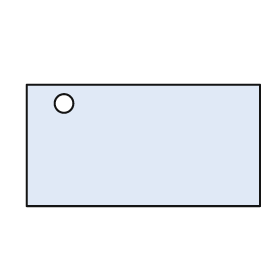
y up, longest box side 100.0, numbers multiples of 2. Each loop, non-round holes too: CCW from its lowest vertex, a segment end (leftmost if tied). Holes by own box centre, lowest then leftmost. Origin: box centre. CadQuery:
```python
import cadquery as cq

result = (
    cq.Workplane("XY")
    .moveTo(-50.0, -26.0)
    .lineTo(50.0, -26.0)
    .lineTo(50.0, 26.0)
    .lineTo(-50.0, 26.0)
    .close()
    .moveTo(-34.0, 18.0)
    .circle(4.0)
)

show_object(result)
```